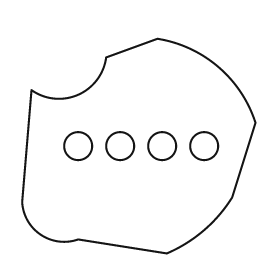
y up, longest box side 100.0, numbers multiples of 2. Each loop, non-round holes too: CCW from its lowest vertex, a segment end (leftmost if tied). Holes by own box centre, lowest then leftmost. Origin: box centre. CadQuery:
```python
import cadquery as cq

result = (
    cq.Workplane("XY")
    .moveTo(12.0, -46.0)
    .threePointArc((28.0, -36.0), (40.0, -22.0))
    .lineTo(50.0, 10.0)
    .threePointArc((34.0, 34.0), (8.0, 46.0))
    .lineTo(-14.0, 38.0)
    .threePointArc((-26.0, 22.0), (-46.0, 24.0))
    .lineTo(-50.0, -24.0)
    .threePointArc((-42.0, -38.0), (-26.0, -40.0))
    .close()
    .moveTo(-26.0, 0.0)
    .circle(6.0)
    .moveTo(-8.0, 0.0)
    .circle(6.0)
    .moveTo(10.0, 0.0)
    .circle(6.0)
    .moveTo(28.0, 0.0)
    .circle(6.0)
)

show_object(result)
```